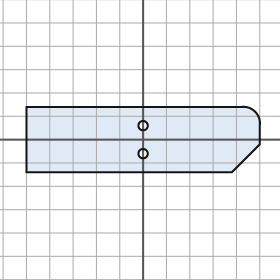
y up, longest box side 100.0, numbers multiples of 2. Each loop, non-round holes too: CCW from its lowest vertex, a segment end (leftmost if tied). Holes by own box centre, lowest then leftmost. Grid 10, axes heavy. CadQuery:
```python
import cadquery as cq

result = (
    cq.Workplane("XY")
    .moveTo(-50.0, -14.0)
    .lineTo(38.0, -14.0)
    .lineTo(50.0, -2.0)
    .lineTo(50.0, 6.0)
    .threePointArc((48.0, 12.0), (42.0, 14.0))
    .lineTo(-50.0, 14.0)
    .close()
    .moveTo(0.0, -6.0)
    .circle(2.0)
    .moveTo(0.0, 6.0)
    .circle(2.0)
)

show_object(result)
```